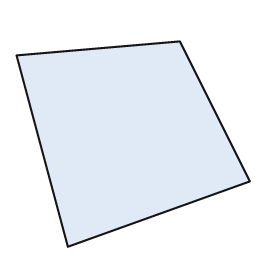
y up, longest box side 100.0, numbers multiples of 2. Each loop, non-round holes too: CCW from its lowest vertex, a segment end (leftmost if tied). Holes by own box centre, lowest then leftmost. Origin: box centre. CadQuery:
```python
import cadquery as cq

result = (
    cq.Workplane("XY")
    .moveTo(-28.0, -44.0)
    .lineTo(50.0, -16.0)
    .lineTo(20.0, 44.0)
    .lineTo(-50.0, 38.0)
    .close()
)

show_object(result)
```